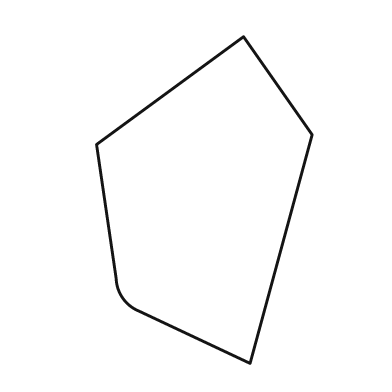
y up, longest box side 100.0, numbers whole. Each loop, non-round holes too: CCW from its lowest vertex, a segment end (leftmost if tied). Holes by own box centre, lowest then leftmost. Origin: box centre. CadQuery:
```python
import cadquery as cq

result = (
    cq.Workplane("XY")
    .moveTo(14.0, -50.0)
    .lineTo(33.0, 20.0)
    .lineTo(12.0, 50.0)
    .lineTo(-33.0, 17.0)
    .lineTo(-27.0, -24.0)
    .threePointArc((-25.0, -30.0), (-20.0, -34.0))
    .close()
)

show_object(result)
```